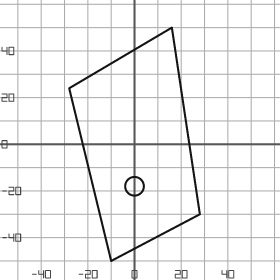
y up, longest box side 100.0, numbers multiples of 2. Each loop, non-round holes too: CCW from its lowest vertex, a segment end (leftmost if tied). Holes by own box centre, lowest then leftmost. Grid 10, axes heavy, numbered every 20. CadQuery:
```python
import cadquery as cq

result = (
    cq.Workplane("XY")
    .moveTo(-10.0, -50.0)
    .lineTo(28.0, -30.0)
    .lineTo(16.0, 50.0)
    .lineTo(-28.0, 24.0)
    .close()
    .moveTo(0.0, -18.0)
    .circle(4.0)
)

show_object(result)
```